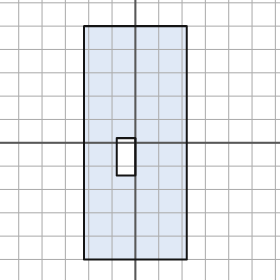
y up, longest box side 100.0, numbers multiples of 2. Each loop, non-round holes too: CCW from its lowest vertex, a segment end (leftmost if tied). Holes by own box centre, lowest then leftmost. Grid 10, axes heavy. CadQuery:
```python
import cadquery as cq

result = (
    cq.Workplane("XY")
    .moveTo(-22.0, -50.0)
    .lineTo(22.0, -50.0)
    .lineTo(22.0, 50.0)
    .lineTo(-22.0, 50.0)
    .close()
    .moveTo(-8.0, -14.0)
    .lineTo(0.0, -14.0)
    .lineTo(0.0, 2.0)
    .lineTo(-8.0, 2.0)
    .close()
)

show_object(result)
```